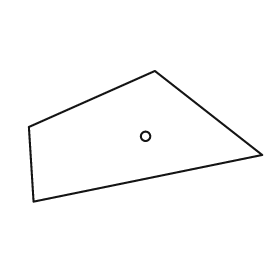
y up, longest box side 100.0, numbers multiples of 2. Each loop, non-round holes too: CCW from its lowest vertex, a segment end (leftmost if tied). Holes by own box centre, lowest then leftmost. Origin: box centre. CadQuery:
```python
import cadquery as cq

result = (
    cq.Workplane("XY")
    .moveTo(-48.0, -28.0)
    .lineTo(50.0, -8.0)
    .lineTo(4.0, 28.0)
    .lineTo(-50.0, 4.0)
    .close()
    .moveTo(0.0, 0.0)
    .circle(2.0)
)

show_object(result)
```